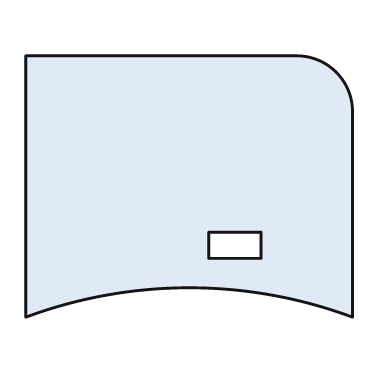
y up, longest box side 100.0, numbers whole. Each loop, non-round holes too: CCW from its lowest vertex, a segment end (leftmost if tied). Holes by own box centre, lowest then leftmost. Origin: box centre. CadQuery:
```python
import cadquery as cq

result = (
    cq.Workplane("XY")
    .moveTo(-50.0, -40.0)
    .threePointArc((0.0, -31.0), (50.0, -40.0))
    .lineTo(50.0, 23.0)
    .threePointArc((45.0, 35.0), (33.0, 40.0))
    .lineTo(-50.0, 40.0)
    .close()
    .moveTo(6.0, -22.0)
    .lineTo(22.0, -22.0)
    .lineTo(22.0, -14.0)
    .lineTo(6.0, -14.0)
    .close()
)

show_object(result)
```